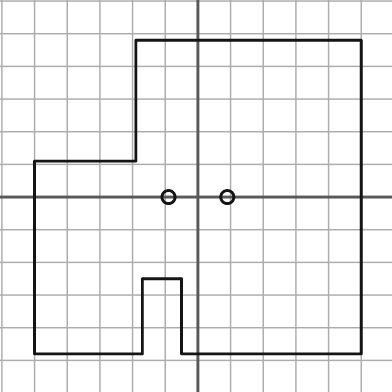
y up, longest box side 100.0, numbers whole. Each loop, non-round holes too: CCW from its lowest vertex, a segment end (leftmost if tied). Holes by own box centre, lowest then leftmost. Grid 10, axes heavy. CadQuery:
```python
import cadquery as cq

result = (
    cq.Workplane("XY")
    .moveTo(-50.0, -48.0)
    .lineTo(-17.0, -48.0)
    .lineTo(-17.0, -25.0)
    .lineTo(-5.0, -25.0)
    .lineTo(-5.0, -48.0)
    .lineTo(50.0, -48.0)
    .lineTo(50.0, 48.0)
    .lineTo(-19.0, 48.0)
    .lineTo(-19.0, 11.0)
    .lineTo(-50.0, 11.0)
    .close()
    .moveTo(-9.0, 0.0)
    .circle(2.0)
    .moveTo(9.0, 0.0)
    .circle(2.0)
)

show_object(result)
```